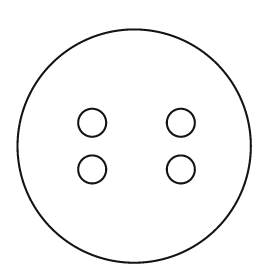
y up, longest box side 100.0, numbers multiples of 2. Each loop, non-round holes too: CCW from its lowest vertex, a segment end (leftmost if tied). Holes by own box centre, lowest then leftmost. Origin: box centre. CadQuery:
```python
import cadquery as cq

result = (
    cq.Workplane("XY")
    .moveTo(0.0, 0.0)
    .circle(50.0)
    .moveTo(-18.0, -10.0)
    .circle(6.0)
    .moveTo(20.0, -10.0)
    .circle(6.0)
    .moveTo(-18.0, 10.0)
    .circle(6.0)
    .moveTo(20.0, 10.0)
    .circle(6.0)
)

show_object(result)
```